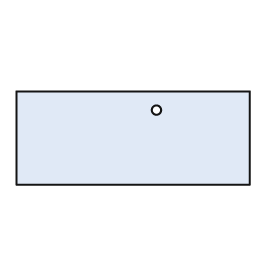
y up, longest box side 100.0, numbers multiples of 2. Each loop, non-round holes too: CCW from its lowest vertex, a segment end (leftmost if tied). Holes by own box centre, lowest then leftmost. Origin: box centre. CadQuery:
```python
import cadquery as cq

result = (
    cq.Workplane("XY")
    .moveTo(-50.0, -20.0)
    .lineTo(50.0, -20.0)
    .lineTo(50.0, 20.0)
    .lineTo(-50.0, 20.0)
    .close()
    .moveTo(10.0, 12.0)
    .circle(2.0)
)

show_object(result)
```